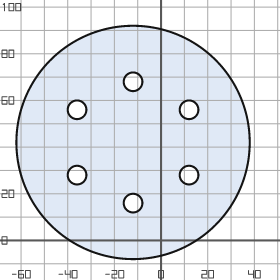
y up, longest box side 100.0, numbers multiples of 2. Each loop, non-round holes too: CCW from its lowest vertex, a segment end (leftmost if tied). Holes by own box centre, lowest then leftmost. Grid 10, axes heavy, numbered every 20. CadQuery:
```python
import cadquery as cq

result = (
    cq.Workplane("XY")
    .moveTo(-12.0, 42.0)
    .circle(50.0)
    .moveTo(-12.0, 16.0)
    .circle(4.0)
    .moveTo(-36.0, 28.0)
    .circle(4.0)
    .moveTo(12.0, 28.0)
    .circle(4.0)
    .moveTo(-36.0, 56.0)
    .circle(4.0)
    .moveTo(12.0, 56.0)
    .circle(4.0)
    .moveTo(-12.0, 68.0)
    .circle(4.0)
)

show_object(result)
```